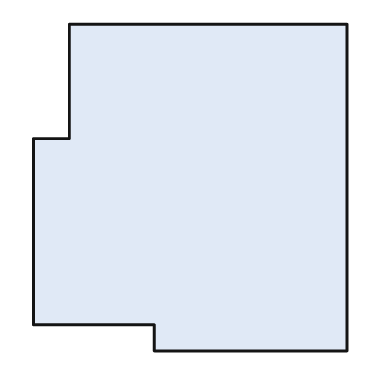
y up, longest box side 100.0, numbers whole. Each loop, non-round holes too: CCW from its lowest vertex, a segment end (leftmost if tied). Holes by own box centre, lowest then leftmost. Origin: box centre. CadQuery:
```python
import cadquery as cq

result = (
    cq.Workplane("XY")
    .moveTo(-11.0, -50.0)
    .lineTo(48.0, -50.0)
    .lineTo(48.0, 50.0)
    .lineTo(-37.0, 50.0)
    .lineTo(-37.0, 15.0)
    .lineTo(-48.0, 15.0)
    .lineTo(-48.0, -42.0)
    .lineTo(-11.0, -42.0)
    .close()
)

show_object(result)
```